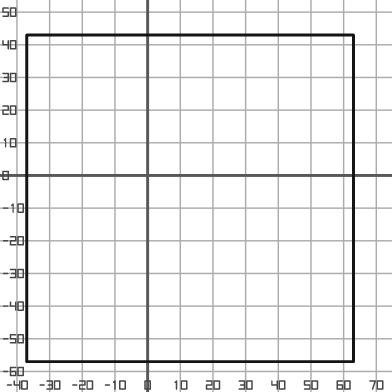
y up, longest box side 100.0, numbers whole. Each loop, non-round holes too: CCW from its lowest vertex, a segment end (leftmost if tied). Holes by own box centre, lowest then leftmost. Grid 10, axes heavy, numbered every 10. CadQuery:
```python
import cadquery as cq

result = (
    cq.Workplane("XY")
    .moveTo(-37.0, -57.0)
    .lineTo(63.0, -57.0)
    .lineTo(63.0, 43.0)
    .lineTo(-37.0, 43.0)
    .close()
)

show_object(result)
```